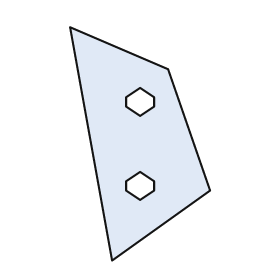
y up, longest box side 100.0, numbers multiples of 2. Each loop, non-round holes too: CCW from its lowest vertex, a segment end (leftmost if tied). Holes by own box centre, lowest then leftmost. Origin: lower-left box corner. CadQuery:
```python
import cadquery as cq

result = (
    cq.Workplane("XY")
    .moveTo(18.0, 0.0)
    .lineTo(60.0, 30.0)
    .lineTo(42.0, 82.0)
    .lineTo(0.0, 100.0)
    .close()
    .moveTo(30.0, 26.0)
    .lineTo(36.0, 30.0)
    .lineTo(36.0, 34.0)
    .lineTo(30.0, 38.0)
    .lineTo(24.0, 34.0)
    .lineTo(24.0, 30.0)
    .close()
    .moveTo(30.0, 62.0)
    .lineTo(36.0, 66.0)
    .lineTo(36.0, 70.0)
    .lineTo(30.0, 74.0)
    .lineTo(24.0, 70.0)
    .lineTo(24.0, 66.0)
    .close()
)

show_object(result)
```